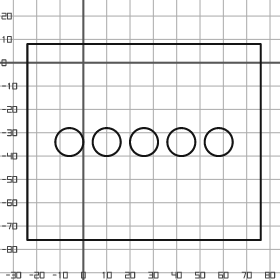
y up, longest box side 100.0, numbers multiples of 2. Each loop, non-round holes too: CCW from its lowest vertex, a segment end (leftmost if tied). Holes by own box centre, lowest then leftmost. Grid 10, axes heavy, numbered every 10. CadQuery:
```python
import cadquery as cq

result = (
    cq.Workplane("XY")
    .moveTo(-24.0, -76.0)
    .lineTo(76.0, -76.0)
    .lineTo(76.0, 8.0)
    .lineTo(-24.0, 8.0)
    .close()
    .moveTo(-6.0, -34.0)
    .circle(6.0)
    .moveTo(10.0, -34.0)
    .circle(6.0)
    .moveTo(26.0, -34.0)
    .circle(6.0)
    .moveTo(42.0, -34.0)
    .circle(6.0)
    .moveTo(58.0, -34.0)
    .circle(6.0)
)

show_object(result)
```